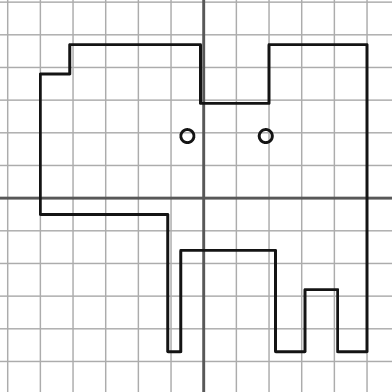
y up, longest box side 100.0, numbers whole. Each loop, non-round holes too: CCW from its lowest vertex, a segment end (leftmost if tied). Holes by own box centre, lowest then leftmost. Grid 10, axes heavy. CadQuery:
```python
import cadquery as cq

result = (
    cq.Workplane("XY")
    .moveTo(-11.0, -47.0)
    .lineTo(-7.0, -47.0)
    .lineTo(-7.0, -16.0)
    .lineTo(22.0, -16.0)
    .lineTo(22.0, -47.0)
    .lineTo(31.0, -47.0)
    .lineTo(31.0, -28.0)
    .lineTo(41.0, -28.0)
    .lineTo(41.0, -47.0)
    .lineTo(50.0, -47.0)
    .lineTo(50.0, 47.0)
    .lineTo(20.0, 47.0)
    .lineTo(20.0, 29.0)
    .lineTo(-1.0, 29.0)
    .lineTo(-1.0, 47.0)
    .lineTo(-41.0, 47.0)
    .lineTo(-41.0, 38.0)
    .lineTo(-50.0, 38.0)
    .lineTo(-50.0, -5.0)
    .lineTo(-11.0, -5.0)
    .close()
    .moveTo(-5.0, 19.0)
    .circle(2.0)
    .moveTo(19.0, 19.0)
    .circle(2.0)
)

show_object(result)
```